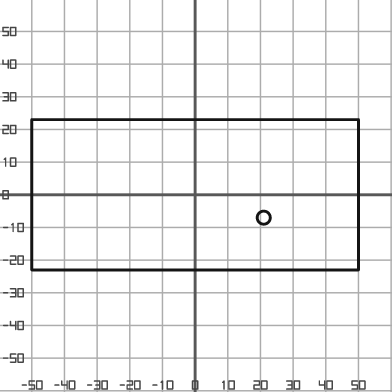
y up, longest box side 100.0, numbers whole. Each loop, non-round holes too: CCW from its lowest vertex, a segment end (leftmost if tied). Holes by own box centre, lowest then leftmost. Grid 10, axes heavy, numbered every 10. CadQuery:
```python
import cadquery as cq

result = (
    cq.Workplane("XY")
    .moveTo(-50.0, -23.0)
    .lineTo(50.0, -23.0)
    .lineTo(50.0, 23.0)
    .lineTo(-50.0, 23.0)
    .close()
    .moveTo(21.0, -7.0)
    .circle(2.0)
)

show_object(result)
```